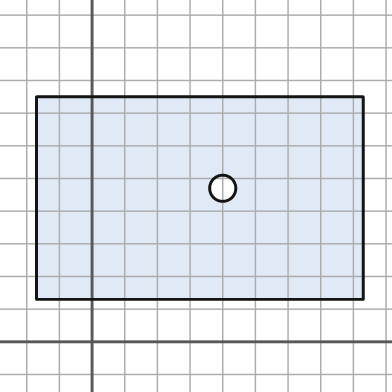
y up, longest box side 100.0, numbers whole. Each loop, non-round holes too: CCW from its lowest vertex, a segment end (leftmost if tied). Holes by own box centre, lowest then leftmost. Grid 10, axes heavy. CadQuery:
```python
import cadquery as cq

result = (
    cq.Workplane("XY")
    .moveTo(-17.0, 13.0)
    .lineTo(83.0, 13.0)
    .lineTo(83.0, 75.0)
    .lineTo(-17.0, 75.0)
    .close()
    .moveTo(40.0, 47.0)
    .circle(4.0)
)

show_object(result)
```